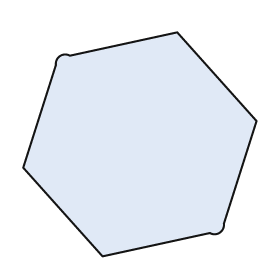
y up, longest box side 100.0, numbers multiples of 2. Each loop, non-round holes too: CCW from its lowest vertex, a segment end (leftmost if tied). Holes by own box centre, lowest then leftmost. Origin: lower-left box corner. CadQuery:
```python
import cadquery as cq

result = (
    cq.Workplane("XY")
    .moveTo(34.0, 0.0)
    .lineTo(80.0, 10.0)
    .threePointArc((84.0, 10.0), (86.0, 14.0))
    .lineTo(100.0, 58.0)
    .lineTo(66.0, 96.0)
    .lineTo(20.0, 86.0)
    .threePointArc((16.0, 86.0), (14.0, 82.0))
    .lineTo(0.0, 38.0)
    .close()
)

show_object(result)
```